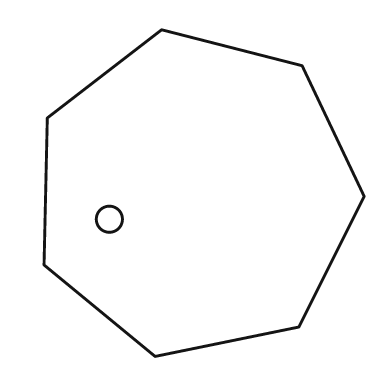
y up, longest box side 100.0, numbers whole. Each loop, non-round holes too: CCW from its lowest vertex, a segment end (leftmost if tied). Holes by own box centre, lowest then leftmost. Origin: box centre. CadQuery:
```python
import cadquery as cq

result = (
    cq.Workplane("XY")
    .moveTo(-15.0, -50.0)
    .lineTo(29.0, -41.0)
    .lineTo(49.0, -1.0)
    .lineTo(30.0, 39.0)
    .lineTo(-13.0, 50.0)
    .lineTo(-48.0, 23.0)
    .lineTo(-49.0, -22.0)
    .close()
    .moveTo(-29.0, -8.0)
    .circle(4.0)
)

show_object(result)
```